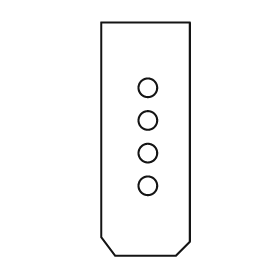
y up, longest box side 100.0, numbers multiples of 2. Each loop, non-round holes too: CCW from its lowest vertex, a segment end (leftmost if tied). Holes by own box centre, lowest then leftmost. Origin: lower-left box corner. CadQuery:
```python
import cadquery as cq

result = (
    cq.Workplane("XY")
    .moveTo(6.0, 0.0)
    .lineTo(32.0, 0.0)
    .lineTo(38.0, 6.0)
    .lineTo(38.0, 100.0)
    .lineTo(0.0, 100.0)
    .lineTo(0.0, 8.0)
    .close()
    .moveTo(20.0, 30.0)
    .circle(4.0)
    .moveTo(20.0, 44.0)
    .circle(4.0)
    .moveTo(20.0, 58.0)
    .circle(4.0)
    .moveTo(20.0, 72.0)
    .circle(4.0)
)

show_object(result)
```